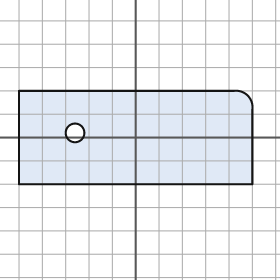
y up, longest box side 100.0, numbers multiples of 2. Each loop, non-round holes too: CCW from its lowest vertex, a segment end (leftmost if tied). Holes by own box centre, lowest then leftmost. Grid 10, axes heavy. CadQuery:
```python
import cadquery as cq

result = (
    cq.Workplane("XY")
    .moveTo(-50.0, -20.0)
    .lineTo(50.0, -20.0)
    .lineTo(50.0, 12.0)
    .threePointArc((48.0, 18.0), (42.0, 20.0))
    .lineTo(-50.0, 20.0)
    .close()
    .moveTo(-26.0, 2.0)
    .circle(4.0)
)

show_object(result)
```